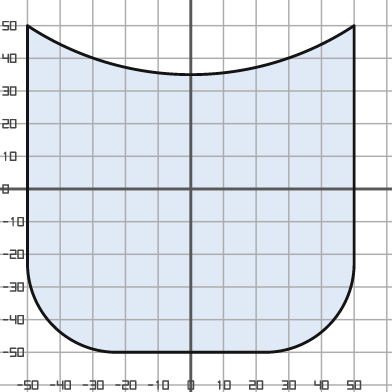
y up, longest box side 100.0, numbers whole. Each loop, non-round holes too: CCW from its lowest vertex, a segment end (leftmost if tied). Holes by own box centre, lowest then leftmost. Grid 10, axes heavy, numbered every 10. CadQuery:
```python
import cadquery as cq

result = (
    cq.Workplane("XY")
    .moveTo(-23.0, -50.0)
    .lineTo(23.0, -50.0)
    .threePointArc((42.0, -42.0), (50.0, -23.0))
    .lineTo(50.0, 50.0)
    .threePointArc((0.0, 35.0), (-50.0, 50.0))
    .lineTo(-50.0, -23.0)
    .threePointArc((-42.0, -42.0), (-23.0, -50.0))
    .close()
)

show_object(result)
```